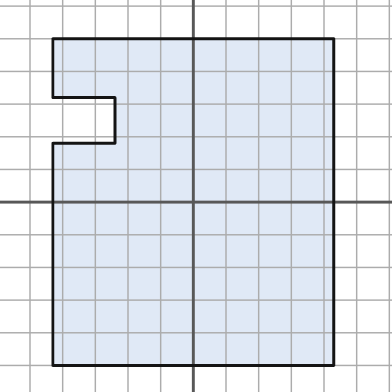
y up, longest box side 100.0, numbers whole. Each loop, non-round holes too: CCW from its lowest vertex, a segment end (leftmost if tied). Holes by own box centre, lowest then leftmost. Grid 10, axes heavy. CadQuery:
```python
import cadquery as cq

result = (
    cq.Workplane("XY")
    .moveTo(-43.0, -50.0)
    .lineTo(43.0, -50.0)
    .lineTo(43.0, 50.0)
    .lineTo(-43.0, 50.0)
    .lineTo(-43.0, 32.0)
    .lineTo(-24.0, 32.0)
    .lineTo(-24.0, 18.0)
    .lineTo(-43.0, 18.0)
    .close()
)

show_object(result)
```